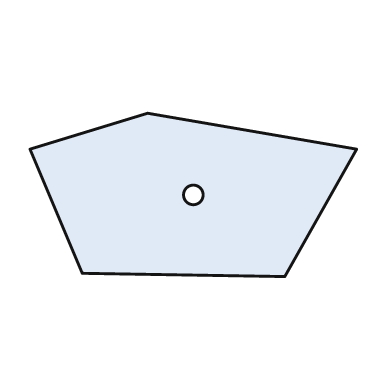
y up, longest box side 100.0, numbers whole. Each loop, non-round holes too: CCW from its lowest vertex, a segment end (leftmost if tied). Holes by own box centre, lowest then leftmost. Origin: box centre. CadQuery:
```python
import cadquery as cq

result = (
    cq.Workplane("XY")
    .moveTo(28.0, -25.0)
    .lineTo(50.0, 14.0)
    .lineTo(-14.0, 25.0)
    .lineTo(-50.0, 14.0)
    .lineTo(-34.0, -24.0)
    .close()
    .moveTo(0.0, 0.0)
    .circle(3.0)
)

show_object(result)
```